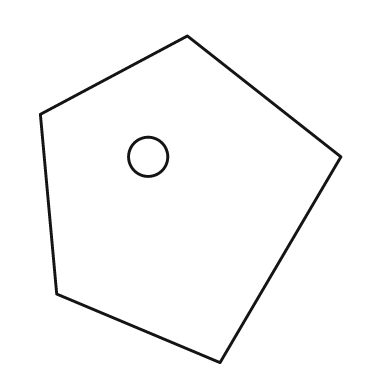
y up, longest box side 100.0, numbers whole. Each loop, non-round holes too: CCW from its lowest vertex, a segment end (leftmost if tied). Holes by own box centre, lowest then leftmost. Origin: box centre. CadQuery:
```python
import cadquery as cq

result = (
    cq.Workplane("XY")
    .moveTo(9.0, -50.0)
    .lineTo(46.0, 13.0)
    .lineTo(-1.0, 50.0)
    .lineTo(-46.0, 26.0)
    .lineTo(-41.0, -29.0)
    .close()
    .moveTo(-13.0, 13.0)
    .circle(6.0)
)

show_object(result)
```